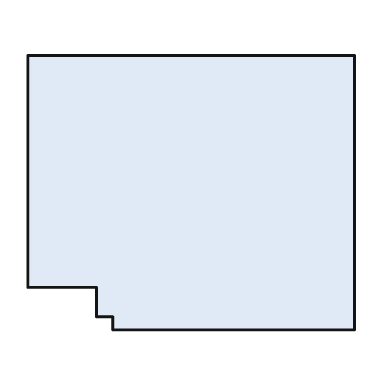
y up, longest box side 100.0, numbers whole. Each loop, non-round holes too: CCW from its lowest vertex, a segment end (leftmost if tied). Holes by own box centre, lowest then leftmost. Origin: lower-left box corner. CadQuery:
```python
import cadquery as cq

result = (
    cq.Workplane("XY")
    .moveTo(26.0, 0.0)
    .lineTo(100.0, 0.0)
    .lineTo(100.0, 84.0)
    .lineTo(0.0, 84.0)
    .lineTo(0.0, 13.0)
    .lineTo(21.0, 13.0)
    .lineTo(21.0, 4.0)
    .lineTo(26.0, 4.0)
    .close()
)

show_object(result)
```